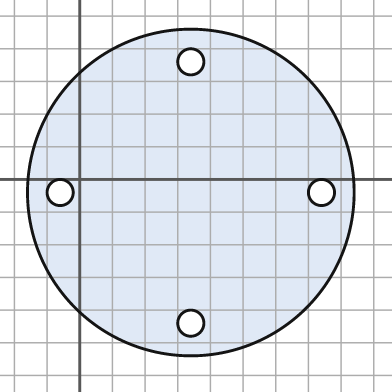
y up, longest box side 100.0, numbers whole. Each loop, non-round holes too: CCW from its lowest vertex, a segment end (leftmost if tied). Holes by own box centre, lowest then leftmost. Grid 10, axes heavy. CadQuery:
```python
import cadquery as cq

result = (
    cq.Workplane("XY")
    .moveTo(34.0, -4.0)
    .circle(50.0)
    .moveTo(34.0, -44.0)
    .circle(4.0)
    .moveTo(-6.0, -4.0)
    .circle(4.0)
    .moveTo(74.0, -4.0)
    .circle(4.0)
    .moveTo(34.0, 36.0)
    .circle(4.0)
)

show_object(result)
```